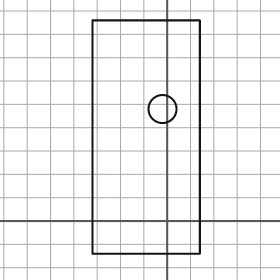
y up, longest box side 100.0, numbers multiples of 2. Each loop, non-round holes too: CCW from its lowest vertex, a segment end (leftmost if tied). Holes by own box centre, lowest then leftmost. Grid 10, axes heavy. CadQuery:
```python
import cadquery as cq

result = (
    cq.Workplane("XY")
    .moveTo(-32.0, -14.0)
    .lineTo(14.0, -14.0)
    .lineTo(14.0, 86.0)
    .lineTo(-32.0, 86.0)
    .close()
    .moveTo(-2.0, 48.0)
    .circle(6.0)
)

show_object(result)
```